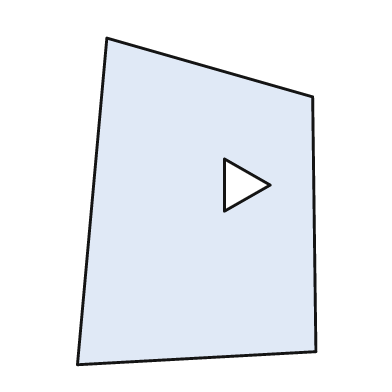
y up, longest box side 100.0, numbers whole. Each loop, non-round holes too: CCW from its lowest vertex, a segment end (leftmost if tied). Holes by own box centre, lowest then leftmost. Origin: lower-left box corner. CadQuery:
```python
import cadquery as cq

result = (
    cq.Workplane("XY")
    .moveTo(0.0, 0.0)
    .lineTo(73.0, 4.0)
    .lineTo(72.0, 82.0)
    .lineTo(9.0, 100.0)
    .close()
    .moveTo(45.0, 47.0)
    .lineTo(59.0, 55.0)
    .lineTo(45.0, 63.0)
    .close()
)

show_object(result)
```